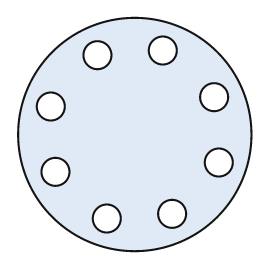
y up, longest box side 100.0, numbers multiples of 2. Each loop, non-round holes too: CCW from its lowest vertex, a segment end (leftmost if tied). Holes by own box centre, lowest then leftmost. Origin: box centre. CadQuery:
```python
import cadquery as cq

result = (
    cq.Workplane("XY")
    .moveTo(0.0, 0.0)
    .circle(50.0)
    .moveTo(-12.0, -36.0)
    .circle(6.0)
    .moveTo(16.0, -34.0)
    .circle(6.0)
    .moveTo(-34.0, -16.0)
    .circle(6.0)
    .moveTo(36.0, -12.0)
    .circle(6.0)
    .moveTo(-36.0, 12.0)
    .circle(6.0)
    .moveTo(34.0, 16.0)
    .circle(6.0)
    .moveTo(-16.0, 34.0)
    .circle(6.0)
    .moveTo(12.0, 36.0)
    .circle(6.0)
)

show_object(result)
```